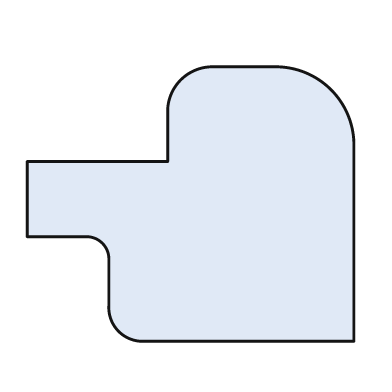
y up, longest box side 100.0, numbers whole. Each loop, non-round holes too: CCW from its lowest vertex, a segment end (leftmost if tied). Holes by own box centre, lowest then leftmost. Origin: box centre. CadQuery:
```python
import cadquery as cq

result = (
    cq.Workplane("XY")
    .moveTo(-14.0, -42.0)
    .lineTo(50.0, -42.0)
    .lineTo(50.0, 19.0)
    .threePointArc((43.0, 35.0), (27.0, 42.0))
    .lineTo(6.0, 42.0)
    .threePointArc((-3.0, 38.0), (-7.0, 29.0))
    .lineTo(-7.0, 13.0)
    .lineTo(-50.0, 13.0)
    .lineTo(-50.0, -10.0)
    .lineTo(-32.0, -10.0)
    .threePointArc((-27.0, -12.0), (-25.0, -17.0))
    .lineTo(-25.0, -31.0)
    .threePointArc((-22.0, -39.0), (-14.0, -42.0))
    .close()
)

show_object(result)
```